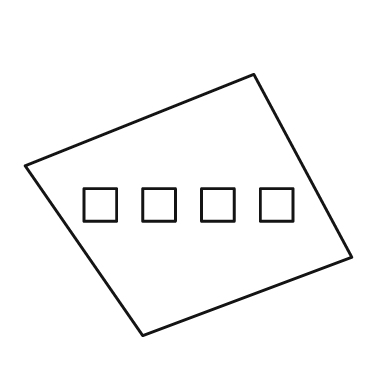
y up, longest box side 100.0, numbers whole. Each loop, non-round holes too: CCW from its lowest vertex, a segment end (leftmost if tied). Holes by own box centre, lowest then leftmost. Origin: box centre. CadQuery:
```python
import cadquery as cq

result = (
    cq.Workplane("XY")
    .moveTo(-14.0, -40.0)
    .lineTo(50.0, -16.0)
    .lineTo(20.0, 40.0)
    .lineTo(-50.0, 12.0)
    .close()
    .moveTo(-32.0, -5.0)
    .lineTo(-22.0, -5.0)
    .lineTo(-22.0, 5.0)
    .lineTo(-32.0, 5.0)
    .close()
    .moveTo(-14.0, -5.0)
    .lineTo(-4.0, -5.0)
    .lineTo(-4.0, 5.0)
    .lineTo(-14.0, 5.0)
    .close()
    .moveTo(4.0, -5.0)
    .lineTo(14.0, -5.0)
    .lineTo(14.0, 5.0)
    .lineTo(4.0, 5.0)
    .close()
    .moveTo(22.0, -5.0)
    .lineTo(32.0, -5.0)
    .lineTo(32.0, 5.0)
    .lineTo(22.0, 5.0)
    .close()
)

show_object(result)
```